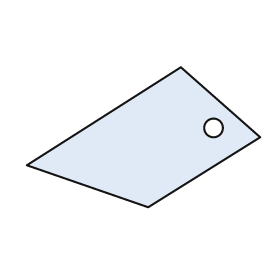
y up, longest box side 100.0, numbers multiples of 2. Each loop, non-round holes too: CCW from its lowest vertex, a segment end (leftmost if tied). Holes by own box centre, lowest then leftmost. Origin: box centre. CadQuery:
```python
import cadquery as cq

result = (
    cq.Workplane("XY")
    .moveTo(2.0, -30.0)
    .lineTo(50.0, 0.0)
    .lineTo(16.0, 30.0)
    .lineTo(-50.0, -12.0)
    .close()
    .moveTo(30.0, 4.0)
    .circle(4.0)
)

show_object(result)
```